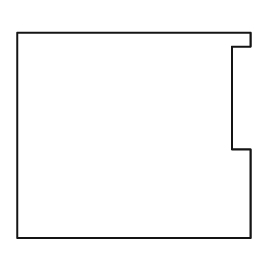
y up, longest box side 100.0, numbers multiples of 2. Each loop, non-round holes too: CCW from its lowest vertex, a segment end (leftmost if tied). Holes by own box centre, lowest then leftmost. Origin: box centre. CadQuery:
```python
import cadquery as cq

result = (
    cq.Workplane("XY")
    .moveTo(-50.0, -44.0)
    .lineTo(50.0, -44.0)
    .lineTo(50.0, -6.0)
    .lineTo(42.0, -6.0)
    .lineTo(42.0, 38.0)
    .lineTo(50.0, 38.0)
    .lineTo(50.0, 44.0)
    .lineTo(-50.0, 44.0)
    .close()
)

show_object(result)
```